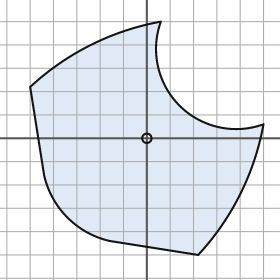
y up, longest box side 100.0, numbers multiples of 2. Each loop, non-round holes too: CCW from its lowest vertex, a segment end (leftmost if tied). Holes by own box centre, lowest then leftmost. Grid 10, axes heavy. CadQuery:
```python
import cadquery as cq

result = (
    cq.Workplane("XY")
    .moveTo(22.0, -50.0)
    .threePointArc((40.0, -24.0), (50.0, 6.0))
    .threePointArc((14.0, 14.0), (6.0, 50.0))
    .threePointArc((-24.0, 40.0), (-50.0, 22.0))
    .lineTo(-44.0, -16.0)
    .threePointArc((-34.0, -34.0), (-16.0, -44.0))
    .close()
    .moveTo(0.0, 0.0)
    .circle(2.0)
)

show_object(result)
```